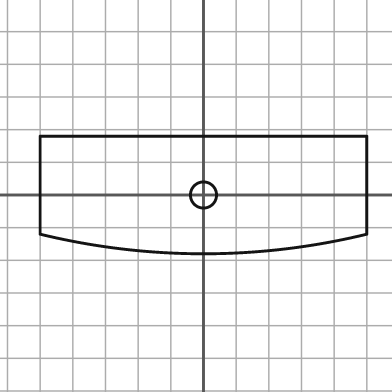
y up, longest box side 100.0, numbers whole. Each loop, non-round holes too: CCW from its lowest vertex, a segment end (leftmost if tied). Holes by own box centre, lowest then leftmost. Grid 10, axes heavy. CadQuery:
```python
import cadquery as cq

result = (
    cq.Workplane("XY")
    .moveTo(-50.0, -12.0)
    .threePointArc((0.0, -18.0), (50.0, -12.0))
    .lineTo(50.0, 18.0)
    .lineTo(-50.0, 18.0)
    .close()
    .moveTo(0.0, 0.0)
    .circle(4.0)
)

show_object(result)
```